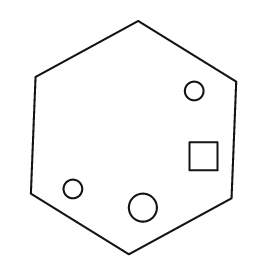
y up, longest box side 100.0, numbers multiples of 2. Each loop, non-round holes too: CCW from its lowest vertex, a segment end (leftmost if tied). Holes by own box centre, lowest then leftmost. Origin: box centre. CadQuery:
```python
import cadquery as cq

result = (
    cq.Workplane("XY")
    .moveTo(-2.0, -50.0)
    .lineTo(42.0, -26.0)
    .lineTo(44.0, 24.0)
    .lineTo(2.0, 50.0)
    .lineTo(-42.0, 26.0)
    .lineTo(-44.0, -24.0)
    .close()
    .moveTo(4.0, -30.0)
    .circle(6.0)
    .moveTo(-26.0, -22.0)
    .circle(4.0)
    .moveTo(24.0, -14.0)
    .lineTo(36.0, -14.0)
    .lineTo(36.0, -2.0)
    .lineTo(24.0, -2.0)
    .close()
    .moveTo(26.0, 20.0)
    .circle(4.0)
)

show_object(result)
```